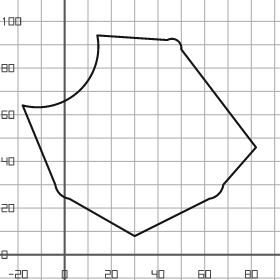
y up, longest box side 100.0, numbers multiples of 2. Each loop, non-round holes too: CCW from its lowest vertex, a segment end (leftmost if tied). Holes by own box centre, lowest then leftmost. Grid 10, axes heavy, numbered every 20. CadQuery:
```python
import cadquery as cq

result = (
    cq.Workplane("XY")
    .moveTo(30.0, 8.0)
    .lineTo(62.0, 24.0)
    .threePointArc((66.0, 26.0), (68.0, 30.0))
    .lineTo(82.0, 46.0)
    .lineTo(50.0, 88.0)
    .threePointArc((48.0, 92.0), (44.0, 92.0))
    .lineTo(14.0, 94.0)
    .threePointArc((6.0, 70.0), (-18.0, 64.0))
    .lineTo(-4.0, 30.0)
    .threePointArc((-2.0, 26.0), (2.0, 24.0))
    .close()
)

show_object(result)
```